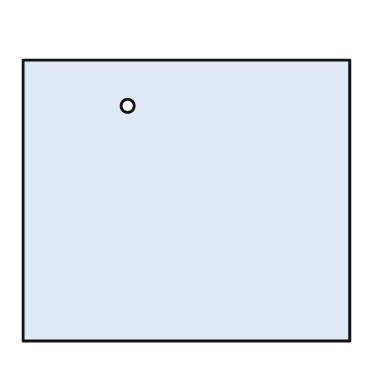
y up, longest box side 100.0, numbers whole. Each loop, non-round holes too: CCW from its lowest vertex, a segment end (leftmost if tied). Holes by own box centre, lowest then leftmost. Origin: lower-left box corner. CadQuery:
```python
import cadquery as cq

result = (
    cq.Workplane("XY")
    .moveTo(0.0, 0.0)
    .lineTo(100.0, 0.0)
    .lineTo(100.0, 86.0)
    .lineTo(0.0, 86.0)
    .close()
    .moveTo(32.0, 72.0)
    .circle(2.0)
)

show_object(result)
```